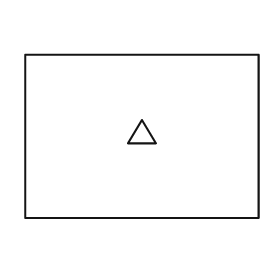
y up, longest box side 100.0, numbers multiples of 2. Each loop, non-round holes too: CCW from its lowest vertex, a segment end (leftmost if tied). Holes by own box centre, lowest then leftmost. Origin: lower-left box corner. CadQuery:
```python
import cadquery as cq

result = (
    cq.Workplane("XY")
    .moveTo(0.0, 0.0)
    .lineTo(100.0, 0.0)
    .lineTo(100.0, 70.0)
    .lineTo(0.0, 70.0)
    .close()
    .moveTo(44.0, 32.0)
    .lineTo(56.0, 32.0)
    .lineTo(50.0, 42.0)
    .close()
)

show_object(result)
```